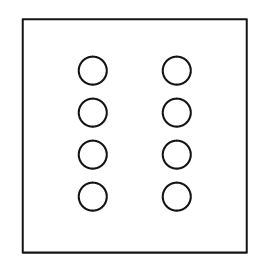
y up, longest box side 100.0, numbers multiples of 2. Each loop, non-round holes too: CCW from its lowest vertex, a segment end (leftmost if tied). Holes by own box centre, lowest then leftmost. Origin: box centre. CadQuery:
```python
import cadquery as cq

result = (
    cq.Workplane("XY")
    .moveTo(-48.0, -50.0)
    .lineTo(48.0, -50.0)
    .lineTo(48.0, 50.0)
    .lineTo(-48.0, 50.0)
    .close()
    .moveTo(-18.0, -26.0)
    .circle(6.0)
    .moveTo(18.0, -26.0)
    .circle(6.0)
    .moveTo(-18.0, -8.0)
    .circle(6.0)
    .moveTo(18.0, -8.0)
    .circle(6.0)
    .moveTo(-18.0, 10.0)
    .circle(6.0)
    .moveTo(18.0, 10.0)
    .circle(6.0)
    .moveTo(-18.0, 28.0)
    .circle(6.0)
    .moveTo(18.0, 28.0)
    .circle(6.0)
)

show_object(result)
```